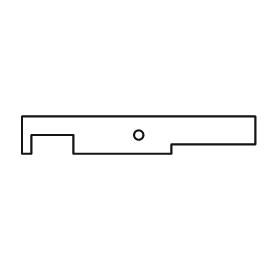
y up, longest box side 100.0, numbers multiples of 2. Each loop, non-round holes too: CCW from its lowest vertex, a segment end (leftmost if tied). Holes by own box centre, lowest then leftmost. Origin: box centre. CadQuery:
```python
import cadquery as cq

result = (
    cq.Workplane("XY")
    .moveTo(-50.0, -8.0)
    .lineTo(-46.0, -8.0)
    .lineTo(-46.0, 0.0)
    .lineTo(-28.0, 0.0)
    .lineTo(-28.0, -8.0)
    .lineTo(14.0, -8.0)
    .lineTo(14.0, -4.0)
    .lineTo(50.0, -4.0)
    .lineTo(50.0, 8.0)
    .lineTo(-50.0, 8.0)
    .close()
    .moveTo(0.0, 0.0)
    .circle(2.0)
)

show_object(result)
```